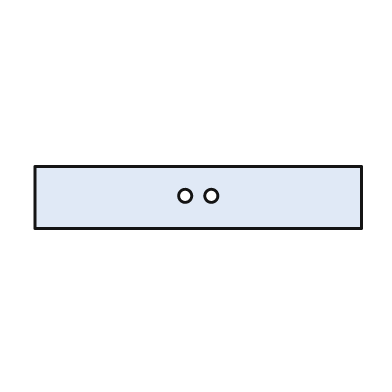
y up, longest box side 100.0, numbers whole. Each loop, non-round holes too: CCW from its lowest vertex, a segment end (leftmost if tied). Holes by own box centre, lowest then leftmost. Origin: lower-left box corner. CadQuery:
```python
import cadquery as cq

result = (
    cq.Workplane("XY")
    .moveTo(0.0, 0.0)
    .lineTo(100.0, 0.0)
    .lineTo(100.0, 19.0)
    .lineTo(0.0, 19.0)
    .close()
    .moveTo(46.0, 10.0)
    .circle(2.0)
    .moveTo(54.0, 10.0)
    .circle(2.0)
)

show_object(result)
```